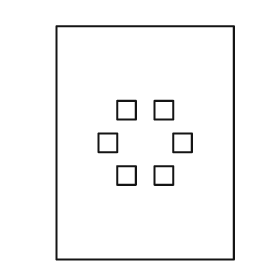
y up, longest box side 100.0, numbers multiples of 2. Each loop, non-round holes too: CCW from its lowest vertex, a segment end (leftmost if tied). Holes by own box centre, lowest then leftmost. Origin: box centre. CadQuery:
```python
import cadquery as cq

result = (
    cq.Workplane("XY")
    .moveTo(-38.0, -50.0)
    .lineTo(38.0, -50.0)
    .lineTo(38.0, 50.0)
    .lineTo(-38.0, 50.0)
    .close()
    .moveTo(-12.0, -18.0)
    .lineTo(-4.0, -18.0)
    .lineTo(-4.0, -10.0)
    .lineTo(-12.0, -10.0)
    .close()
    .moveTo(4.0, -18.0)
    .lineTo(12.0, -18.0)
    .lineTo(12.0, -10.0)
    .lineTo(4.0, -10.0)
    .close()
    .moveTo(-20.0, -4.0)
    .lineTo(-12.0, -4.0)
    .lineTo(-12.0, 4.0)
    .lineTo(-20.0, 4.0)
    .close()
    .moveTo(12.0, -4.0)
    .lineTo(20.0, -4.0)
    .lineTo(20.0, 4.0)
    .lineTo(12.0, 4.0)
    .close()
    .moveTo(-12.0, 10.0)
    .lineTo(-4.0, 10.0)
    .lineTo(-4.0, 18.0)
    .lineTo(-12.0, 18.0)
    .close()
    .moveTo(4.0, 10.0)
    .lineTo(12.0, 10.0)
    .lineTo(12.0, 18.0)
    .lineTo(4.0, 18.0)
    .close()
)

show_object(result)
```